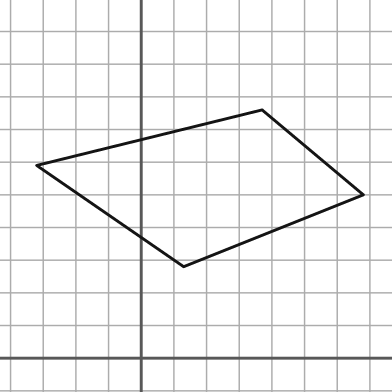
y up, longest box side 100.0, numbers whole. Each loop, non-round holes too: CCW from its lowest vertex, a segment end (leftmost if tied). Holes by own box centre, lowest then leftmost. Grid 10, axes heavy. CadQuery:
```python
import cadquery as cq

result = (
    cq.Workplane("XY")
    .moveTo(13.0, 28.0)
    .lineTo(68.0, 50.0)
    .lineTo(37.0, 76.0)
    .lineTo(-32.0, 59.0)
    .close()
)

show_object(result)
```